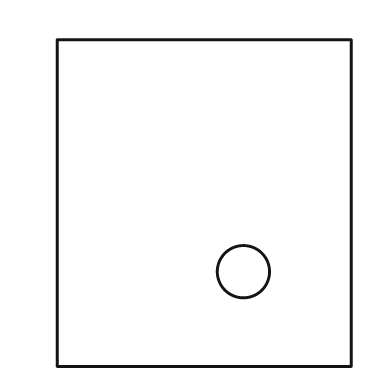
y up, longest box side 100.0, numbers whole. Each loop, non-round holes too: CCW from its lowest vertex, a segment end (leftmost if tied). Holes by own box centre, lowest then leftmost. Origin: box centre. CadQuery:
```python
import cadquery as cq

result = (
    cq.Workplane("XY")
    .moveTo(-45.0, -50.0)
    .lineTo(45.0, -50.0)
    .lineTo(45.0, 50.0)
    .lineTo(-45.0, 50.0)
    .close()
    .moveTo(12.0, -21.0)
    .circle(8.0)
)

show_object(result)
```